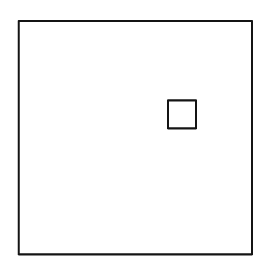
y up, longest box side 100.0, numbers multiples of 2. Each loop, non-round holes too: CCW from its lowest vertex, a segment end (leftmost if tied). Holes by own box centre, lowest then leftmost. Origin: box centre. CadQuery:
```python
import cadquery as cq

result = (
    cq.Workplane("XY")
    .moveTo(-50.0, -50.0)
    .lineTo(50.0, -50.0)
    .lineTo(50.0, 50.0)
    .lineTo(-50.0, 50.0)
    .close()
    .moveTo(14.0, 4.0)
    .lineTo(26.0, 4.0)
    .lineTo(26.0, 16.0)
    .lineTo(14.0, 16.0)
    .close()
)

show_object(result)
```